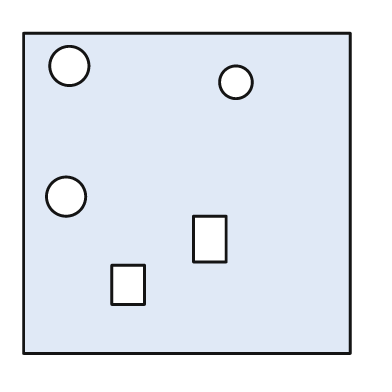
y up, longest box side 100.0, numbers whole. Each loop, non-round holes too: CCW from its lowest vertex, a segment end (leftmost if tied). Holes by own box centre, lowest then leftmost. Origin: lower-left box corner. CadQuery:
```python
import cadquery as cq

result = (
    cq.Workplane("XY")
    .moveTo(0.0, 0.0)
    .lineTo(100.0, 0.0)
    .lineTo(100.0, 98.0)
    .lineTo(0.0, 98.0)
    .close()
    .moveTo(27.0, 15.0)
    .lineTo(37.0, 15.0)
    .lineTo(37.0, 27.0)
    .lineTo(27.0, 27.0)
    .close()
    .moveTo(52.0, 28.0)
    .lineTo(62.0, 28.0)
    .lineTo(62.0, 42.0)
    .lineTo(52.0, 42.0)
    .close()
    .moveTo(13.0, 48.0)
    .circle(6.0)
    .moveTo(65.0, 83.0)
    .circle(5.0)
    .moveTo(14.0, 88.0)
    .circle(6.0)
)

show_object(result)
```